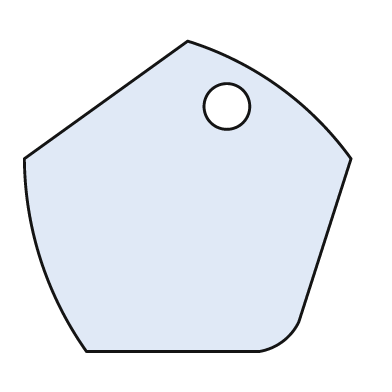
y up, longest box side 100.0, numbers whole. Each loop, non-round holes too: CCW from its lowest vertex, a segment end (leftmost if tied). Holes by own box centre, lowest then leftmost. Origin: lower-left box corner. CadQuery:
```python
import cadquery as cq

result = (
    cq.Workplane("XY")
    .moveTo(19.0, 0.0)
    .lineTo(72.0, 0.0)
    .threePointArc((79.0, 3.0), (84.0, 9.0))
    .lineTo(100.0, 59.0)
    .threePointArc((78.0, 81.0), (50.0, 95.0))
    .lineTo(0.0, 59.0)
    .threePointArc((5.0, 28.0), (19.0, 0.0))
    .close()
    .moveTo(62.0, 75.0)
    .circle(7.0)
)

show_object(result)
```